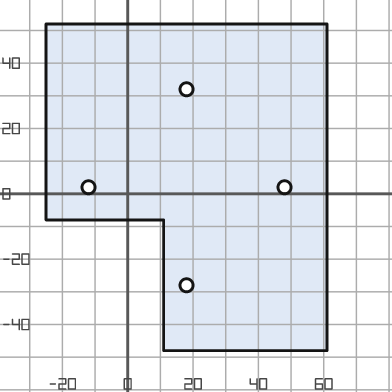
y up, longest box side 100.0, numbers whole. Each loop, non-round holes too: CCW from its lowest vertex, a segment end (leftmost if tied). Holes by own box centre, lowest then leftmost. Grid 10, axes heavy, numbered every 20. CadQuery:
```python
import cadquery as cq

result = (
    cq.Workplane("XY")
    .moveTo(11.0, -48.0)
    .lineTo(61.0, -48.0)
    .lineTo(61.0, 52.0)
    .lineTo(-25.0, 52.0)
    .lineTo(-25.0, -8.0)
    .lineTo(11.0, -8.0)
    .close()
    .moveTo(18.0, -28.0)
    .circle(2.0)
    .moveTo(-12.0, 2.0)
    .circle(2.0)
    .moveTo(48.0, 2.0)
    .circle(2.0)
    .moveTo(18.0, 32.0)
    .circle(2.0)
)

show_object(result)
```